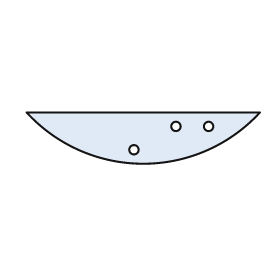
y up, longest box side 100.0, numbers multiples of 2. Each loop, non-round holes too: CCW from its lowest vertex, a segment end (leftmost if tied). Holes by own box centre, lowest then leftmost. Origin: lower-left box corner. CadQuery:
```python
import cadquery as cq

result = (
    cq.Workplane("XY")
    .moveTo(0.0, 22.0)
    .threePointArc((50.0, 0.0), (100.0, 22.0))
    .close()
    .moveTo(46.0, 6.0)
    .circle(2.0)
    .moveTo(64.0, 16.0)
    .circle(2.0)
    .moveTo(78.0, 16.0)
    .circle(2.0)
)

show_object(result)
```